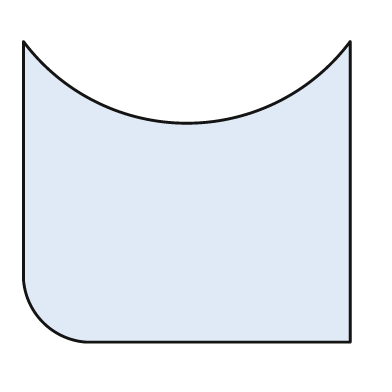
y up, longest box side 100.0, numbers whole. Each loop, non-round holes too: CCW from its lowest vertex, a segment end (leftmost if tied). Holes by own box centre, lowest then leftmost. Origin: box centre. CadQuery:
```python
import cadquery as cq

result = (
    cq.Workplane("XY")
    .moveTo(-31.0, -46.0)
    .lineTo(50.0, -46.0)
    .lineTo(50.0, 46.0)
    .threePointArc((0.0, 21.0), (-50.0, 46.0))
    .lineTo(-50.0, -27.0)
    .threePointArc((-44.0, -40.0), (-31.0, -46.0))
    .close()
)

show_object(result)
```